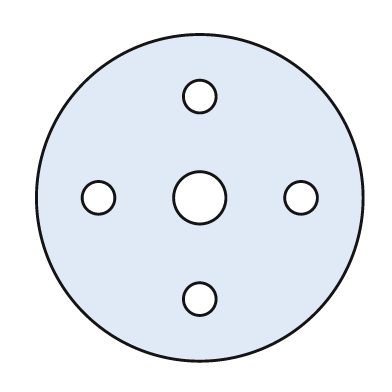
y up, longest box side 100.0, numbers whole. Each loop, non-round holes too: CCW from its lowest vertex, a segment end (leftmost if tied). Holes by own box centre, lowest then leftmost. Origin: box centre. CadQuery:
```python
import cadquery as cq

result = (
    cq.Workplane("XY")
    .moveTo(0.0, 0.0)
    .circle(50.0)
    .moveTo(0.0, -31.0)
    .circle(5.0)
    .moveTo(-31.0, 0.0)
    .circle(5.0)
    .moveTo(0.0, 0.0)
    .circle(8.0)
    .moveTo(31.0, 0.0)
    .circle(5.0)
    .moveTo(0.0, 31.0)
    .circle(5.0)
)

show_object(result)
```